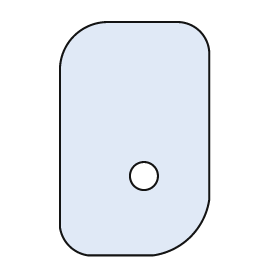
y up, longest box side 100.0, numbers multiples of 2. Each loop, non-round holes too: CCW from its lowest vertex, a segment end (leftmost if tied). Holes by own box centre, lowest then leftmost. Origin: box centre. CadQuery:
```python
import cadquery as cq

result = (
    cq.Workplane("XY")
    .moveTo(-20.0, -50.0)
    .lineTo(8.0, -50.0)
    .threePointArc((24.0, -42.0), (32.0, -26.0))
    .lineTo(32.0, 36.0)
    .threePointArc((28.0, 46.0), (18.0, 50.0))
    .lineTo(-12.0, 50.0)
    .threePointArc((-26.0, 44.0), (-32.0, 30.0))
    .lineTo(-32.0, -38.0)
    .threePointArc((-28.0, -46.0), (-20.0, -50.0))
    .close()
    .moveTo(4.0, -16.0)
    .circle(6.0)
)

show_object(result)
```